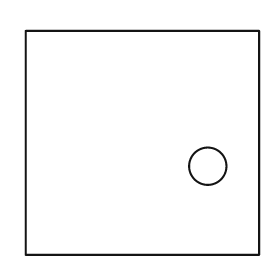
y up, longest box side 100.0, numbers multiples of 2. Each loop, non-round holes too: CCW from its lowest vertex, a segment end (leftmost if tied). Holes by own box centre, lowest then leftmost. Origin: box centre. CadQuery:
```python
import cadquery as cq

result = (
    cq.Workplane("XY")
    .moveTo(-50.0, -48.0)
    .lineTo(50.0, -48.0)
    .lineTo(50.0, 48.0)
    .lineTo(-50.0, 48.0)
    .close()
    .moveTo(28.0, -10.0)
    .circle(8.0)
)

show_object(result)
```